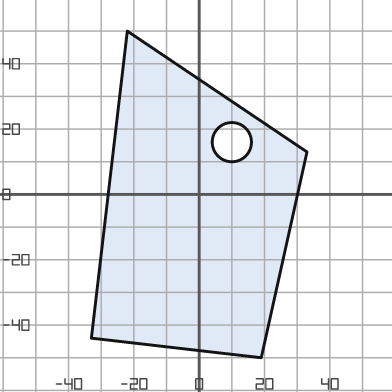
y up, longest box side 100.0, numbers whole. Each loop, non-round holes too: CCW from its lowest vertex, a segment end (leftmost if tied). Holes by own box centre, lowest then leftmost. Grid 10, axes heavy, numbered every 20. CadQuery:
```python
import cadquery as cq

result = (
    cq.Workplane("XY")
    .moveTo(19.0, -50.0)
    .lineTo(33.0, 13.0)
    .lineTo(-22.0, 50.0)
    .lineTo(-33.0, -44.0)
    .close()
    .moveTo(10.0, 16.0)
    .circle(6.0)
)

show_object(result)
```